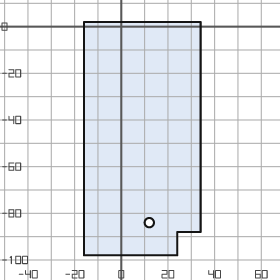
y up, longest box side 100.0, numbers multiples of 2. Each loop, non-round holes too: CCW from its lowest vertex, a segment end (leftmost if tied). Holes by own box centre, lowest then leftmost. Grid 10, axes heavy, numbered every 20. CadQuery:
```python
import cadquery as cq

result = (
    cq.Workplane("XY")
    .moveTo(-16.0, -98.0)
    .lineTo(24.0, -98.0)
    .lineTo(24.0, -88.0)
    .lineTo(34.0, -88.0)
    .lineTo(34.0, 2.0)
    .lineTo(-16.0, 2.0)
    .close()
    .moveTo(12.0, -84.0)
    .circle(2.0)
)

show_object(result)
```